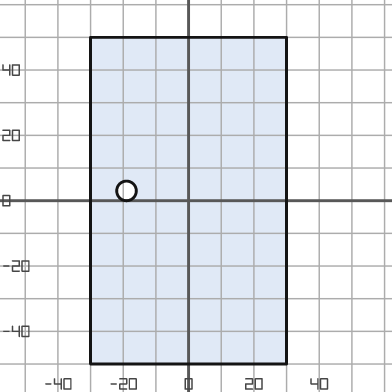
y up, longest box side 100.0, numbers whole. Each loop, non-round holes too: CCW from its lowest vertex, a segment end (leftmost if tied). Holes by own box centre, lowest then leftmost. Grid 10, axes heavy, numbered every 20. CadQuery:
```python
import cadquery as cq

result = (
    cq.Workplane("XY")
    .moveTo(-30.0, -50.0)
    .lineTo(30.0, -50.0)
    .lineTo(30.0, 50.0)
    .lineTo(-30.0, 50.0)
    .close()
    .moveTo(-19.0, 3.0)
    .circle(3.0)
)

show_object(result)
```